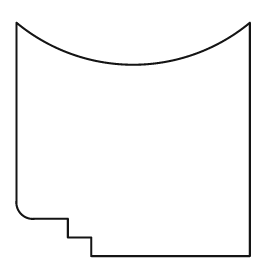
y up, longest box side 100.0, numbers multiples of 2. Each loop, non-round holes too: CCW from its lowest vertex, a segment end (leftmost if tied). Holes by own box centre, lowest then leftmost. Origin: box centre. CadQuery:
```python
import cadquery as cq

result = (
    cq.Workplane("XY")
    .moveTo(-18.0, -50.0)
    .lineTo(50.0, -50.0)
    .lineTo(50.0, 50.0)
    .threePointArc((0.0, 32.0), (-50.0, 50.0))
    .lineTo(-50.0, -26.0)
    .threePointArc((-48.0, -32.0), (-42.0, -34.0))
    .lineTo(-28.0, -34.0)
    .lineTo(-28.0, -42.0)
    .lineTo(-18.0, -42.0)
    .close()
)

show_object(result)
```